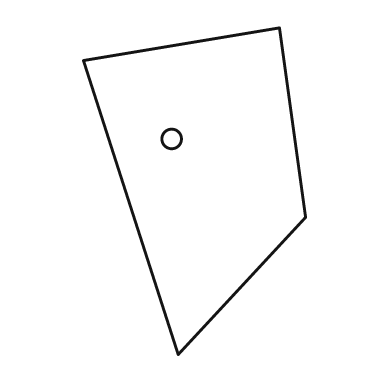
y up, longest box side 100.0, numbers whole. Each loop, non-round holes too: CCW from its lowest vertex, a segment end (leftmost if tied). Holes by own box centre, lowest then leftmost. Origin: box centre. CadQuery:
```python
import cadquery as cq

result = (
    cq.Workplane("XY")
    .moveTo(-5.0, -50.0)
    .lineTo(34.0, -8.0)
    .lineTo(26.0, 50.0)
    .lineTo(-34.0, 40.0)
    .close()
    .moveTo(-7.0, 16.0)
    .circle(3.0)
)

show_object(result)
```